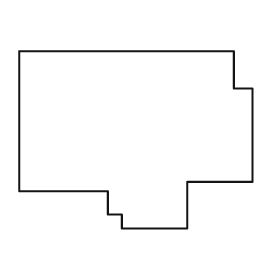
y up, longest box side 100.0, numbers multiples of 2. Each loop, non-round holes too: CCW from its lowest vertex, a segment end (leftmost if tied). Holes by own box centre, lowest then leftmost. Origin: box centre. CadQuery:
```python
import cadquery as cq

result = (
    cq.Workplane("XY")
    .moveTo(-6.0, -38.0)
    .lineTo(22.0, -38.0)
    .lineTo(22.0, -18.0)
    .lineTo(50.0, -18.0)
    .lineTo(50.0, 22.0)
    .lineTo(42.0, 22.0)
    .lineTo(42.0, 38.0)
    .lineTo(-50.0, 38.0)
    .lineTo(-50.0, -22.0)
    .lineTo(-12.0, -22.0)
    .lineTo(-12.0, -32.0)
    .lineTo(-6.0, -32.0)
    .close()
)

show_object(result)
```